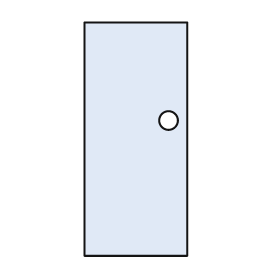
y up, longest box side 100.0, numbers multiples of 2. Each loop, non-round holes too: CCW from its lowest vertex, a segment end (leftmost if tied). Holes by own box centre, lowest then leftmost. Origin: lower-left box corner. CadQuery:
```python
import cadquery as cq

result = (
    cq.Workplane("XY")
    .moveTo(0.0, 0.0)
    .lineTo(44.0, 0.0)
    .lineTo(44.0, 100.0)
    .lineTo(0.0, 100.0)
    .close()
    .moveTo(36.0, 58.0)
    .circle(4.0)
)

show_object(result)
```